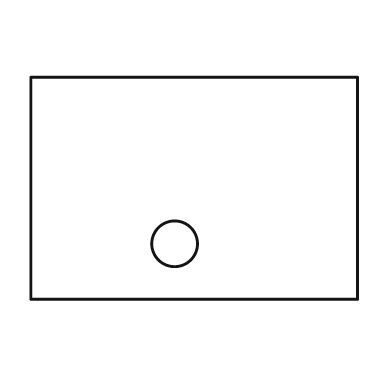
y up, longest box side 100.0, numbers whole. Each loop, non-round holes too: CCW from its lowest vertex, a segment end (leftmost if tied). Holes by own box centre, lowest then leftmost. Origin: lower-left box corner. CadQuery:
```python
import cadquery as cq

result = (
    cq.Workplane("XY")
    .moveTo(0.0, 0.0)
    .lineTo(100.0, 0.0)
    .lineTo(100.0, 68.0)
    .lineTo(0.0, 68.0)
    .close()
    .moveTo(44.0, 17.0)
    .circle(7.0)
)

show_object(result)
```